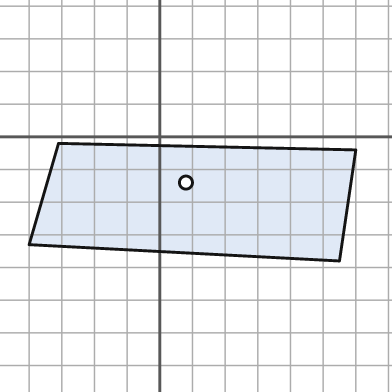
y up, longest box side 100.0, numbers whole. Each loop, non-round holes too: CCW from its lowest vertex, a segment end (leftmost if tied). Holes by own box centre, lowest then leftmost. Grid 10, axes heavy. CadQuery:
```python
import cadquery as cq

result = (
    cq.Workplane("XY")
    .moveTo(55.0, -38.0)
    .lineTo(60.0, -4.0)
    .lineTo(-31.0, -2.0)
    .lineTo(-40.0, -33.0)
    .close()
    .moveTo(8.0, -14.0)
    .circle(2.0)
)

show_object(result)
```